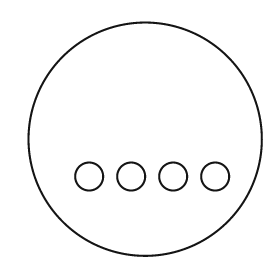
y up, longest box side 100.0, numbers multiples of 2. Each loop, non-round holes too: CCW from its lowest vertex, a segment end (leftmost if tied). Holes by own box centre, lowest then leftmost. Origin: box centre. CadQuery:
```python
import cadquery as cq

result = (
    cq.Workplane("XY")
    .moveTo(0.0, 0.0)
    .circle(50.0)
    .moveTo(-24.0, -16.0)
    .circle(6.0)
    .moveTo(-6.0, -16.0)
    .circle(6.0)
    .moveTo(12.0, -16.0)
    .circle(6.0)
    .moveTo(30.0, -16.0)
    .circle(6.0)
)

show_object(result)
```